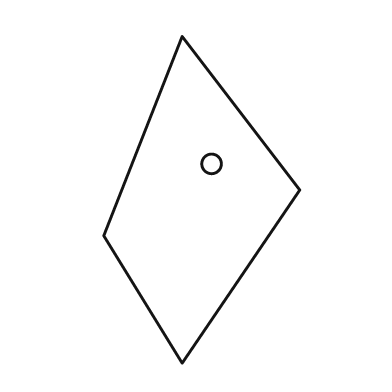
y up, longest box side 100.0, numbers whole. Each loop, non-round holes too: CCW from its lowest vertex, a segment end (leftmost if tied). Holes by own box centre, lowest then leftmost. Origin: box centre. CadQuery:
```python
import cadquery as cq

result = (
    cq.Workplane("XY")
    .moveTo(-6.0, -50.0)
    .lineTo(30.0, 3.0)
    .lineTo(-6.0, 50.0)
    .lineTo(-30.0, -11.0)
    .close()
    .moveTo(3.0, 11.0)
    .circle(3.0)
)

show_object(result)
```